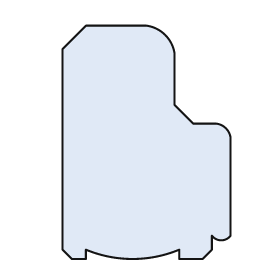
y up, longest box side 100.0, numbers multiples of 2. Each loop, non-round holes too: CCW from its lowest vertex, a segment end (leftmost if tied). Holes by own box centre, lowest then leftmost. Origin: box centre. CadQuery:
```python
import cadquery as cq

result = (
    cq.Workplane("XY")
    .moveTo(-32.0, -50.0)
    .lineTo(-26.0, -50.0)
    .lineTo(-26.0, -46.0)
    .threePointArc((-6.0, -50.0), (14.0, -46.0))
    .lineTo(14.0, -50.0)
    .lineTo(24.0, -50.0)
    .lineTo(28.0, -46.0)
    .lineTo(28.0, -40.0)
    .threePointArc((32.0, -42.0), (36.0, -40.0))
    .lineTo(36.0, 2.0)
    .threePointArc((34.0, 6.0), (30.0, 8.0))
    .lineTo(20.0, 8.0)
    .lineTo(12.0, 16.0)
    .lineTo(12.0, 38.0)
    .threePointArc((8.0, 46.0), (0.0, 50.0))
    .lineTo(-26.0, 50.0)
    .lineTo(-36.0, 40.0)
    .lineTo(-36.0, -46.0)
    .close()
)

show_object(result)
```